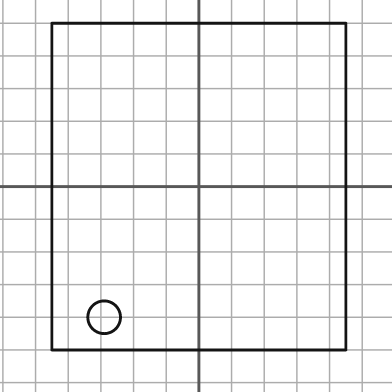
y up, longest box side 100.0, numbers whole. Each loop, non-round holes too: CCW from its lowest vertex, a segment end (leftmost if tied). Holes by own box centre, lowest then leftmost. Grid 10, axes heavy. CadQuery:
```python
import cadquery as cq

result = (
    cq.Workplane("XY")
    .moveTo(-45.0, -50.0)
    .lineTo(45.0, -50.0)
    .lineTo(45.0, 50.0)
    .lineTo(-45.0, 50.0)
    .close()
    .moveTo(-29.0, -40.0)
    .circle(5.0)
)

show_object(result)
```